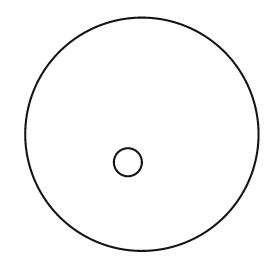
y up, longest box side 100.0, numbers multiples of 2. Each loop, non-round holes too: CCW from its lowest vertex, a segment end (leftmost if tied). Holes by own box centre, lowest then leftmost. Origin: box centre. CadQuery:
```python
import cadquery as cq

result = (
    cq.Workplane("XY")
    .moveTo(0.0, 0.0)
    .circle(50.0)
    .moveTo(-6.0, -12.0)
    .circle(6.0)
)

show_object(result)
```